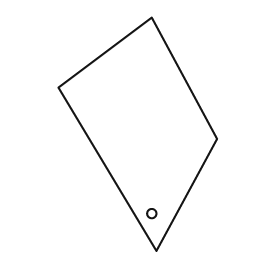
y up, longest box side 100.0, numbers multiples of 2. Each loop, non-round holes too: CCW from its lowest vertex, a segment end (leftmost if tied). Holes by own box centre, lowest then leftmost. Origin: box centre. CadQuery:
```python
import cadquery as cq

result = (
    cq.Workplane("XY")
    .moveTo(8.0, -50.0)
    .lineTo(34.0, -2.0)
    .lineTo(6.0, 50.0)
    .lineTo(-34.0, 20.0)
    .close()
    .moveTo(6.0, -34.0)
    .circle(2.0)
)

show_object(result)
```